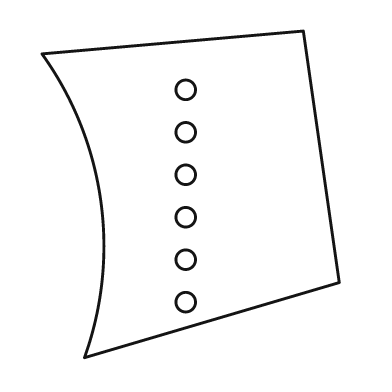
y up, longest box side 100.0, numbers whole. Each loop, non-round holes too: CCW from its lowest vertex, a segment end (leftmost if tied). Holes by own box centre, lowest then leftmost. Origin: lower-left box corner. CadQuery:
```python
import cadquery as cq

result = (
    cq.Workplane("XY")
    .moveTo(13.0, 0.0)
    .lineTo(91.0, 23.0)
    .lineTo(80.0, 100.0)
    .lineTo(0.0, 93.0)
    .threePointArc((18.0, 48.0), (13.0, 0.0))
    .close()
    .moveTo(44.0, 17.0)
    .circle(3.0)
    .moveTo(44.0, 30.0)
    .circle(3.0)
    .moveTo(44.0, 43.0)
    .circle(3.0)
    .moveTo(44.0, 56.0)
    .circle(3.0)
    .moveTo(44.0, 69.0)
    .circle(3.0)
    .moveTo(44.0, 82.0)
    .circle(3.0)
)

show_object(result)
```